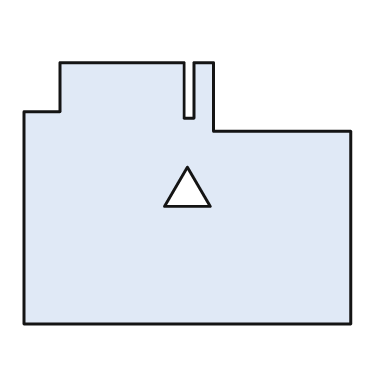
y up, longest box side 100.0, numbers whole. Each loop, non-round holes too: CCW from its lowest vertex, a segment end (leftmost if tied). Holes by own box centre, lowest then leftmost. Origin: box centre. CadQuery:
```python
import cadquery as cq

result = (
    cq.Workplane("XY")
    .moveTo(-50.0, -40.0)
    .lineTo(50.0, -40.0)
    .lineTo(50.0, 19.0)
    .lineTo(8.0, 19.0)
    .lineTo(8.0, 40.0)
    .lineTo(2.0, 40.0)
    .lineTo(2.0, 23.0)
    .lineTo(-1.0, 23.0)
    .lineTo(-1.0, 40.0)
    .lineTo(-39.0, 40.0)
    .lineTo(-39.0, 25.0)
    .lineTo(-50.0, 25.0)
    .close()
    .moveTo(-7.0, -4.0)
    .lineTo(7.0, -4.0)
    .lineTo(0.0, 8.0)
    .close()
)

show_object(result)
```